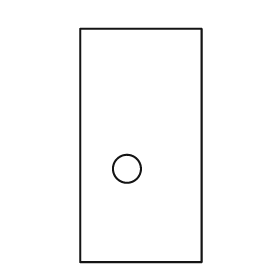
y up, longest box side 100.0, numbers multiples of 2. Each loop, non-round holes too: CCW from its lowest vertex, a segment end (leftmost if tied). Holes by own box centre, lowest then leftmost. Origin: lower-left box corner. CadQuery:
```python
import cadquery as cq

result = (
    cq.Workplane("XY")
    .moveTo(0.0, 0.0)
    .lineTo(52.0, 0.0)
    .lineTo(52.0, 100.0)
    .lineTo(0.0, 100.0)
    .close()
    .moveTo(20.0, 40.0)
    .circle(6.0)
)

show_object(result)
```